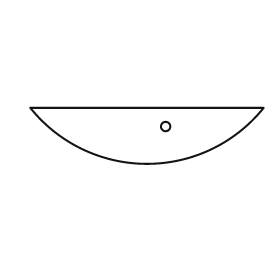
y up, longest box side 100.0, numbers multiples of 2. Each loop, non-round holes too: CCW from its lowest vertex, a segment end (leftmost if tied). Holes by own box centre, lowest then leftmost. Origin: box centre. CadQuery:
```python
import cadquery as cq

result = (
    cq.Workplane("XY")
    .moveTo(-50.0, 12.0)
    .threePointArc((0.0, -12.0), (50.0, 12.0))
    .close()
    .moveTo(8.0, 4.0)
    .circle(2.0)
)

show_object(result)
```